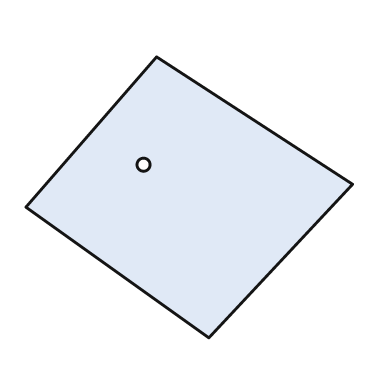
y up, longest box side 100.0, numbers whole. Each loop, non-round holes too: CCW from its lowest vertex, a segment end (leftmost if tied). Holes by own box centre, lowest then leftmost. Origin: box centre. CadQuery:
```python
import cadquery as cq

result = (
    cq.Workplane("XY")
    .moveTo(6.0, -43.0)
    .lineTo(50.0, 4.0)
    .lineTo(-10.0, 43.0)
    .lineTo(-50.0, -3.0)
    .close()
    .moveTo(-14.0, 10.0)
    .circle(2.0)
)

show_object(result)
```